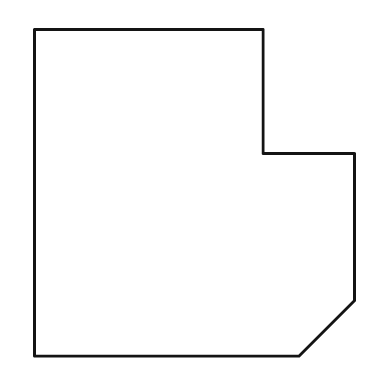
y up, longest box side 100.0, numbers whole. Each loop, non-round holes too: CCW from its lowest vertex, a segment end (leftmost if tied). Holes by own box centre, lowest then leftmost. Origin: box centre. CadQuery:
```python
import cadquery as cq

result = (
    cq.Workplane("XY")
    .moveTo(-49.0, -50.0)
    .lineTo(32.0, -50.0)
    .lineTo(49.0, -33.0)
    .lineTo(49.0, 12.0)
    .lineTo(21.0, 12.0)
    .lineTo(21.0, 50.0)
    .lineTo(-49.0, 50.0)
    .close()
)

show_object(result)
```